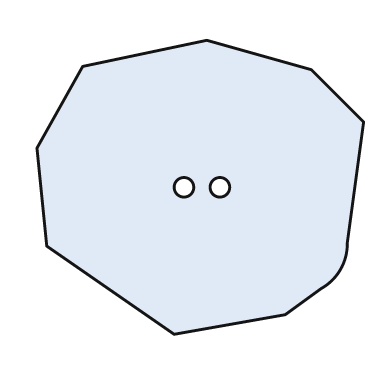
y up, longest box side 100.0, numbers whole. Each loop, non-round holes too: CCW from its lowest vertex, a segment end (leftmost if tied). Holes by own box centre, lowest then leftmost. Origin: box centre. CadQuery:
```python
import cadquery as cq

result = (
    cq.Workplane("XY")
    .moveTo(-8.0, -45.0)
    .lineTo(26.0, -39.0)
    .lineTo(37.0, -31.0)
    .threePointArc((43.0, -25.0), (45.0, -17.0))
    .lineTo(50.0, 20.0)
    .lineTo(34.0, 36.0)
    .lineTo(2.0, 45.0)
    .lineTo(-36.0, 37.0)
    .lineTo(-50.0, 12.0)
    .lineTo(-47.0, -18.0)
    .close()
    .moveTo(-5.0, 0.0)
    .circle(3.0)
    .moveTo(6.0, 0.0)
    .circle(3.0)
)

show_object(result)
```